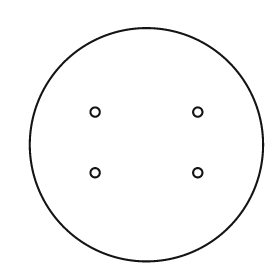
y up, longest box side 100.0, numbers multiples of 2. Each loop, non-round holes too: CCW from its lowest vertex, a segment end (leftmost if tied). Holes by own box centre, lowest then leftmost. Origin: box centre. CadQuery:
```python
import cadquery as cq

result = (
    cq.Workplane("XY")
    .moveTo(0.0, 0.0)
    .circle(50.0)
    .moveTo(-22.0, -12.0)
    .circle(2.0)
    .moveTo(22.0, -12.0)
    .circle(2.0)
    .moveTo(-22.0, 14.0)
    .circle(2.0)
    .moveTo(22.0, 14.0)
    .circle(2.0)
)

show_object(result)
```